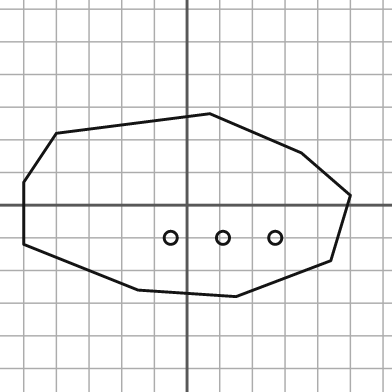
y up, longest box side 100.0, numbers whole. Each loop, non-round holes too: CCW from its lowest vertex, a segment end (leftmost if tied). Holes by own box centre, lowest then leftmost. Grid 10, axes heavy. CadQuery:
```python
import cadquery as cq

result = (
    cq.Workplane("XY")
    .moveTo(15.0, -28.0)
    .lineTo(44.0, -17.0)
    .lineTo(50.0, 3.0)
    .lineTo(35.0, 16.0)
    .lineTo(7.0, 28.0)
    .lineTo(-40.0, 22.0)
    .lineTo(-50.0, 7.0)
    .lineTo(-50.0, -12.0)
    .lineTo(-15.0, -26.0)
    .close()
    .moveTo(-5.0, -10.0)
    .circle(2.0)
    .moveTo(11.0, -10.0)
    .circle(2.0)
    .moveTo(27.0, -10.0)
    .circle(2.0)
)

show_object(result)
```